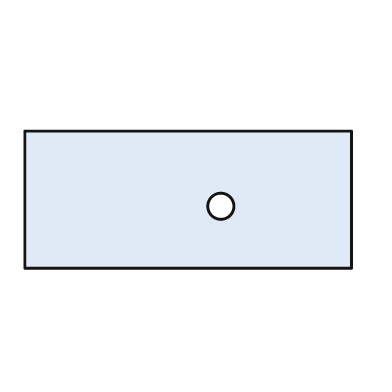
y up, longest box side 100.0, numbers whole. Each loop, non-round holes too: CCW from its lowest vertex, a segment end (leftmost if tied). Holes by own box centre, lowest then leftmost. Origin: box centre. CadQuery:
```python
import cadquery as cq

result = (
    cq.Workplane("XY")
    .moveTo(-50.0, -21.0)
    .lineTo(50.0, -21.0)
    .lineTo(50.0, 21.0)
    .lineTo(-50.0, 21.0)
    .close()
    .moveTo(10.0, -2.0)
    .circle(4.0)
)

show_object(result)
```